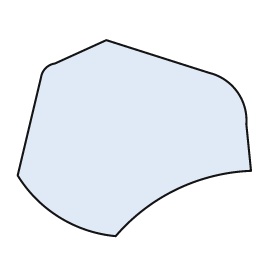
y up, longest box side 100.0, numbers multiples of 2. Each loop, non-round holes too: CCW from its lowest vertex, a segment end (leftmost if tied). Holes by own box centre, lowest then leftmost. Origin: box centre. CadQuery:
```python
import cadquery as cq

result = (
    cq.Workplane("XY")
    .moveTo(-8.0, -42.0)
    .threePointArc((18.0, -22.0), (50.0, -14.0))
    .lineTo(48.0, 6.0)
    .threePointArc((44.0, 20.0), (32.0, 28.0))
    .lineTo(-12.0, 42.0)
    .lineTo(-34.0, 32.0)
    .threePointArc((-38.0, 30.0), (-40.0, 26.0))
    .lineTo(-50.0, -16.0)
    .threePointArc((-32.0, -34.0), (-8.0, -42.0))
    .close()
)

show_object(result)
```